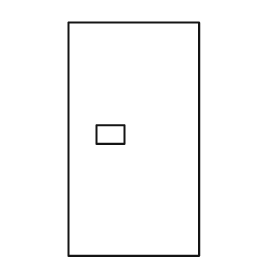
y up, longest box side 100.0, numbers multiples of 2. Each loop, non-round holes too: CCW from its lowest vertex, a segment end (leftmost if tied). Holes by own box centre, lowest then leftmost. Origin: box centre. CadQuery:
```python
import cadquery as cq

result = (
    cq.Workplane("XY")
    .moveTo(-28.0, -50.0)
    .lineTo(28.0, -50.0)
    .lineTo(28.0, 50.0)
    .lineTo(-28.0, 50.0)
    .close()
    .moveTo(-16.0, -2.0)
    .lineTo(-4.0, -2.0)
    .lineTo(-4.0, 6.0)
    .lineTo(-16.0, 6.0)
    .close()
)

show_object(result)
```